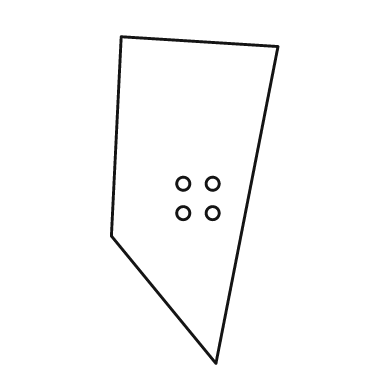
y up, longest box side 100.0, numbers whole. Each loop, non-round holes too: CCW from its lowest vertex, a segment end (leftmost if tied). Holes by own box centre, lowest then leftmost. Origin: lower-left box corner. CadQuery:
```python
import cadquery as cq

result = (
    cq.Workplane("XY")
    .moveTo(32.0, 0.0)
    .lineTo(51.0, 97.0)
    .lineTo(3.0, 100.0)
    .lineTo(0.0, 39.0)
    .close()
    .moveTo(22.0, 46.0)
    .circle(2.0)
    .moveTo(31.0, 46.0)
    .circle(2.0)
    .moveTo(22.0, 55.0)
    .circle(2.0)
    .moveTo(31.0, 55.0)
    .circle(2.0)
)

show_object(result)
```